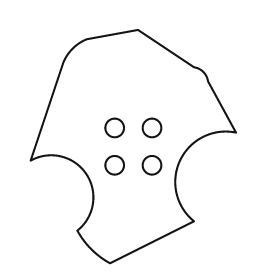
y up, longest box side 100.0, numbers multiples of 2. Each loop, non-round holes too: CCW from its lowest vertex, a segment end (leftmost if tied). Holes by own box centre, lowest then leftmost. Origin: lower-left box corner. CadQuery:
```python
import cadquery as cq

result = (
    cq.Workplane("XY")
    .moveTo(34.0, 0.0)
    .lineTo(70.0, 18.0)
    .threePointArc((64.0, 44.0), (88.0, 56.0))
    .lineTo(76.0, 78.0)
    .threePointArc((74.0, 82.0), (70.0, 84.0))
    .lineTo(46.0, 100.0)
    .lineTo(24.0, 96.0)
    .threePointArc((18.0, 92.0), (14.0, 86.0))
    .lineTo(0.0, 44.0)
    .threePointArc((24.0, 38.0), (20.0, 14.0))
    .threePointArc((26.0, 6.0), (34.0, 0.0))
    .close()
    .moveTo(36.0, 42.0)
    .circle(4.0)
    .moveTo(52.0, 42.0)
    .circle(4.0)
    .moveTo(36.0, 58.0)
    .circle(4.0)
    .moveTo(52.0, 58.0)
    .circle(4.0)
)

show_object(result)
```